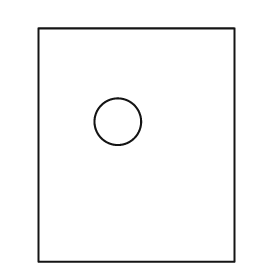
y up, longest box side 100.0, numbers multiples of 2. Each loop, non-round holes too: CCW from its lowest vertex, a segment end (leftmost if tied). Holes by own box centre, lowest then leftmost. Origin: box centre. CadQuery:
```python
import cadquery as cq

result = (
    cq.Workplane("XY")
    .moveTo(-42.0, -50.0)
    .lineTo(42.0, -50.0)
    .lineTo(42.0, 50.0)
    .lineTo(-42.0, 50.0)
    .close()
    .moveTo(-8.0, 10.0)
    .circle(10.0)
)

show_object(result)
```